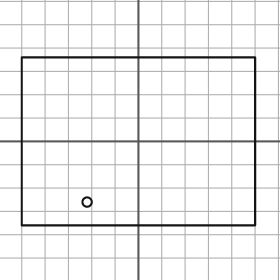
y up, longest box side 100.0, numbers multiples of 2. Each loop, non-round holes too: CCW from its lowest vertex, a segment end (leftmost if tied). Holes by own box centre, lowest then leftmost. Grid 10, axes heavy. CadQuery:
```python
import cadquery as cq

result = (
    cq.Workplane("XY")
    .moveTo(-50.0, -36.0)
    .lineTo(50.0, -36.0)
    .lineTo(50.0, 36.0)
    .lineTo(-50.0, 36.0)
    .close()
    .moveTo(-22.0, -26.0)
    .circle(2.0)
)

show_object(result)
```